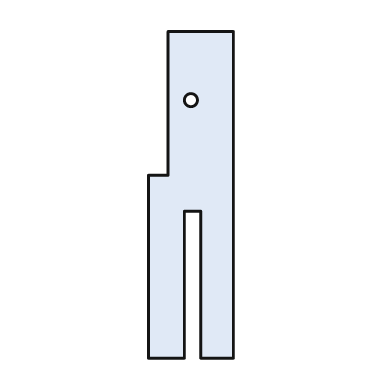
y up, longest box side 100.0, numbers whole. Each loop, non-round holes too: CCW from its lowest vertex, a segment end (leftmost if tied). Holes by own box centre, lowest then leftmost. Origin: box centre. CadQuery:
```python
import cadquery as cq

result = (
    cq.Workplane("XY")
    .moveTo(-13.0, -50.0)
    .lineTo(-2.0, -50.0)
    .lineTo(-2.0, -5.0)
    .lineTo(3.0, -5.0)
    .lineTo(3.0, -50.0)
    .lineTo(13.0, -50.0)
    .lineTo(13.0, 50.0)
    .lineTo(-7.0, 50.0)
    .lineTo(-7.0, 6.0)
    .lineTo(-13.0, 6.0)
    .close()
    .moveTo(0.0, 29.0)
    .circle(2.0)
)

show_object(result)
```